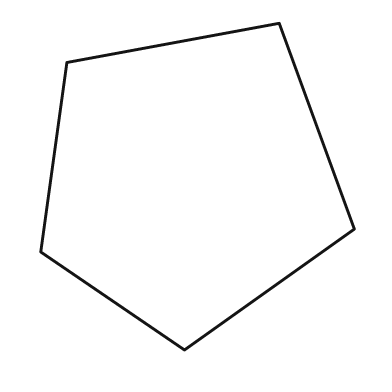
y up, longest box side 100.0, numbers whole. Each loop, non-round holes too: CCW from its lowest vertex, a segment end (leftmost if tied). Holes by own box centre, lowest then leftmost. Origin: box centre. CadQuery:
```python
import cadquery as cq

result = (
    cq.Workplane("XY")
    .moveTo(-4.0, -50.0)
    .lineTo(48.0, -13.0)
    .lineTo(25.0, 50.0)
    .lineTo(-40.0, 38.0)
    .lineTo(-48.0, -20.0)
    .close()
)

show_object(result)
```